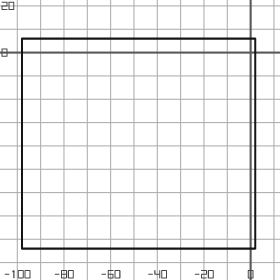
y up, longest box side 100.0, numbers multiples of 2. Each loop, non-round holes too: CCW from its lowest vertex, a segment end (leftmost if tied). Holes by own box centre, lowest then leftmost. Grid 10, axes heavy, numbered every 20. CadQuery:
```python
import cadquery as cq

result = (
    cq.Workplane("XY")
    .moveTo(-98.0, -84.0)
    .lineTo(2.0, -84.0)
    .lineTo(2.0, 6.0)
    .lineTo(-98.0, 6.0)
    .close()
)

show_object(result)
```